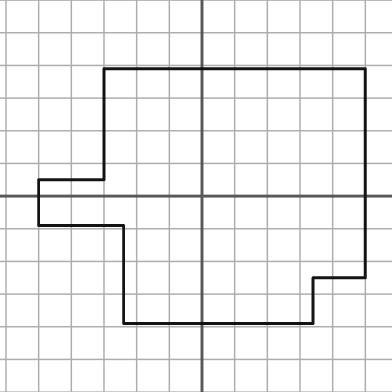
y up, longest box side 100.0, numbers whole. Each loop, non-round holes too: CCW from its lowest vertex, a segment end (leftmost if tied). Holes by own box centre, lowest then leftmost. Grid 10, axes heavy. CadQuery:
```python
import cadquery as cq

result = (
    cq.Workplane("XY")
    .moveTo(-24.0, -39.0)
    .lineTo(34.0, -39.0)
    .lineTo(34.0, -25.0)
    .lineTo(50.0, -25.0)
    .lineTo(50.0, 39.0)
    .lineTo(-30.0, 39.0)
    .lineTo(-30.0, 5.0)
    .lineTo(-50.0, 5.0)
    .lineTo(-50.0, -9.0)
    .lineTo(-24.0, -9.0)
    .close()
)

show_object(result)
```